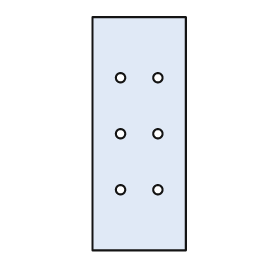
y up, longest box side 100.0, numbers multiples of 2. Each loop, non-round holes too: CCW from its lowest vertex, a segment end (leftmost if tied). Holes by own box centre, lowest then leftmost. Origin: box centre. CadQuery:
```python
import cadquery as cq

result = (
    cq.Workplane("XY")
    .moveTo(-20.0, -50.0)
    .lineTo(20.0, -50.0)
    .lineTo(20.0, 50.0)
    .lineTo(-20.0, 50.0)
    .close()
    .moveTo(-8.0, -24.0)
    .circle(2.0)
    .moveTo(8.0, -24.0)
    .circle(2.0)
    .moveTo(-8.0, 0.0)
    .circle(2.0)
    .moveTo(8.0, 0.0)
    .circle(2.0)
    .moveTo(-8.0, 24.0)
    .circle(2.0)
    .moveTo(8.0, 24.0)
    .circle(2.0)
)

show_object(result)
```